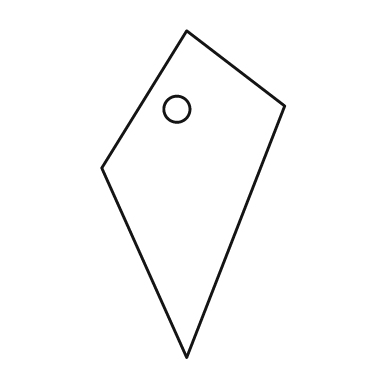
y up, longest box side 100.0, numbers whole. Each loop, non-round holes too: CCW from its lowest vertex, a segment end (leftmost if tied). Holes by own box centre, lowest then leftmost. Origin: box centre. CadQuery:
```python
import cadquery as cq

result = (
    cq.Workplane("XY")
    .moveTo(-2.0, -50.0)
    .lineTo(28.0, 27.0)
    .lineTo(-2.0, 50.0)
    .lineTo(-28.0, 8.0)
    .close()
    .moveTo(-5.0, 26.0)
    .circle(4.0)
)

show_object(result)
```